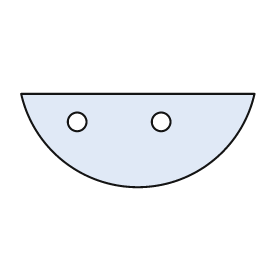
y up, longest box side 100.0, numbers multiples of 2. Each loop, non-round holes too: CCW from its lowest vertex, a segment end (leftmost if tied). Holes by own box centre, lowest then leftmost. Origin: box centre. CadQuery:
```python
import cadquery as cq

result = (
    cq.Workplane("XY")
    .moveTo(-50.0, 20.0)
    .threePointArc((0.0, -20.0), (50.0, 20.0))
    .close()
    .moveTo(-26.0, 8.0)
    .circle(4.0)
    .moveTo(10.0, 8.0)
    .circle(4.0)
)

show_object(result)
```